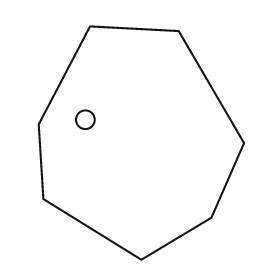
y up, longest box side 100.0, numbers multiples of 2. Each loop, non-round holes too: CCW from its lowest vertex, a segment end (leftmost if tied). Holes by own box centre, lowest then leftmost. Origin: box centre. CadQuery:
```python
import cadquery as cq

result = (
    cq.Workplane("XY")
    .moveTo(0.0, -50.0)
    .lineTo(30.0, -32.0)
    .lineTo(44.0, 0.0)
    .lineTo(16.0, 48.0)
    .lineTo(-22.0, 50.0)
    .lineTo(-44.0, 8.0)
    .lineTo(-42.0, -24.0)
    .close()
    .moveTo(-24.0, 10.0)
    .circle(4.0)
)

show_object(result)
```